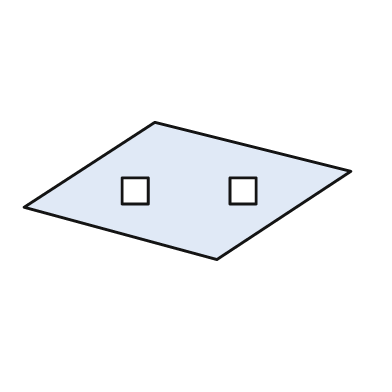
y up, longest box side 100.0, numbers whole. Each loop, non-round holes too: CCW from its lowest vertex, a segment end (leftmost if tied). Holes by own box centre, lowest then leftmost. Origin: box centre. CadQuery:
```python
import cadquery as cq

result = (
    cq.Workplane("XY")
    .moveTo(9.0, -21.0)
    .lineTo(50.0, 6.0)
    .lineTo(-10.0, 21.0)
    .lineTo(-50.0, -5.0)
    .close()
    .moveTo(-20.0, -4.0)
    .lineTo(-12.0, -4.0)
    .lineTo(-12.0, 4.0)
    .lineTo(-20.0, 4.0)
    .close()
    .moveTo(13.0, -4.0)
    .lineTo(21.0, -4.0)
    .lineTo(21.0, 4.0)
    .lineTo(13.0, 4.0)
    .close()
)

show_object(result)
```